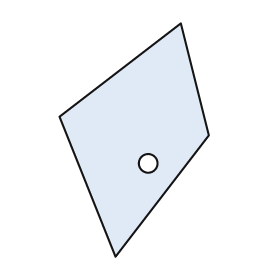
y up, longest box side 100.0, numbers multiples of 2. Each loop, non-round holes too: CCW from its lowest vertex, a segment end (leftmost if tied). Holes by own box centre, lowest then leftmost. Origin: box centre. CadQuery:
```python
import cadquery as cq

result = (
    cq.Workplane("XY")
    .moveTo(-8.0, -50.0)
    .lineTo(32.0, 2.0)
    .lineTo(20.0, 50.0)
    .lineTo(-32.0, 10.0)
    .close()
    .moveTo(6.0, -10.0)
    .circle(4.0)
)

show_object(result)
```